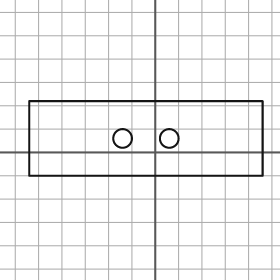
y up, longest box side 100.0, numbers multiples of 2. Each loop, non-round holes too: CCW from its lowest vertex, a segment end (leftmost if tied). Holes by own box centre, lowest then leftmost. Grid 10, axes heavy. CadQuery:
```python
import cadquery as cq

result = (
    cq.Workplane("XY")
    .moveTo(-54.0, -10.0)
    .lineTo(46.0, -10.0)
    .lineTo(46.0, 22.0)
    .lineTo(-54.0, 22.0)
    .close()
    .moveTo(-14.0, 6.0)
    .circle(4.0)
    .moveTo(6.0, 6.0)
    .circle(4.0)
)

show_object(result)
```